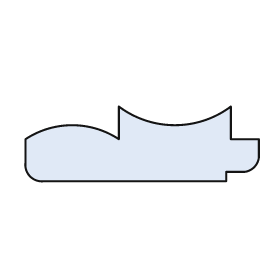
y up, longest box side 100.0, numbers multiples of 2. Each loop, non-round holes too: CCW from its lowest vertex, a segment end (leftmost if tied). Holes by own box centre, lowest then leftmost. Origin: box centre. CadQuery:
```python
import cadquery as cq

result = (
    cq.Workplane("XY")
    .moveTo(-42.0, -16.0)
    .lineTo(36.0, -16.0)
    .lineTo(36.0, -12.0)
    .lineTo(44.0, -12.0)
    .threePointArc((48.0, -10.0), (50.0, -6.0))
    .lineTo(50.0, 2.0)
    .lineTo(38.0, 2.0)
    .lineTo(38.0, 16.0)
    .threePointArc((14.0, 8.0), (-10.0, 16.0))
    .lineTo(-10.0, 2.0)
    .threePointArc((-30.0, 8.0), (-50.0, 2.0))
    .lineTo(-50.0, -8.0)
    .threePointArc((-48.0, -14.0), (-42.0, -16.0))
    .close()
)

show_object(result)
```